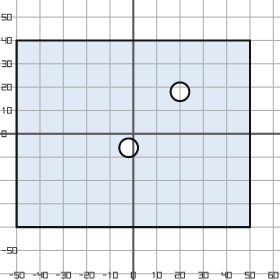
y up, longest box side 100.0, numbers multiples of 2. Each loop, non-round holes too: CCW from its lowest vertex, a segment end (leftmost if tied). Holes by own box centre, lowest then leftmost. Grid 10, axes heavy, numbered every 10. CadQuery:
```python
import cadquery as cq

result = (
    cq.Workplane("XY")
    .moveTo(-50.0, -40.0)
    .lineTo(50.0, -40.0)
    .lineTo(50.0, 40.0)
    .lineTo(-50.0, 40.0)
    .close()
    .moveTo(-2.0, -6.0)
    .circle(4.0)
    .moveTo(20.0, 18.0)
    .circle(4.0)
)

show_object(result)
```